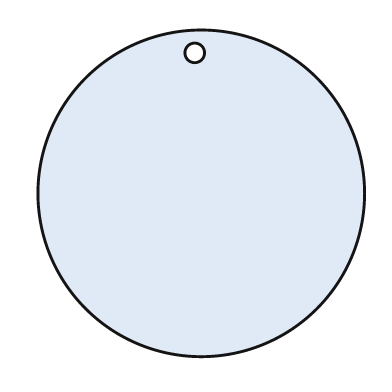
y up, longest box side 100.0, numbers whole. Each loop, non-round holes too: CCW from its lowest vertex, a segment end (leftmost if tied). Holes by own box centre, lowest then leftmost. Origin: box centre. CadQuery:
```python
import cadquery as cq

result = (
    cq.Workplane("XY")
    .moveTo(0.0, 0.0)
    .circle(50.0)
    .moveTo(-2.0, 43.0)
    .circle(3.0)
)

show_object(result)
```